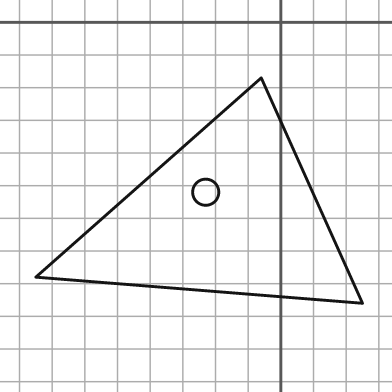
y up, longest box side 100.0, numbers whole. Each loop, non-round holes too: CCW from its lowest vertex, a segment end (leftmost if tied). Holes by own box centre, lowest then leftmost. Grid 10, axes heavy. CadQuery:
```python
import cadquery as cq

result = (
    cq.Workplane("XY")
    .moveTo(25.0, -86.0)
    .lineTo(-6.0, -17.0)
    .lineTo(-75.0, -78.0)
    .close()
    .moveTo(-23.0, -52.0)
    .circle(4.0)
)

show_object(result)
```